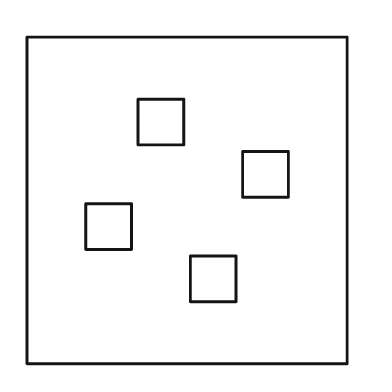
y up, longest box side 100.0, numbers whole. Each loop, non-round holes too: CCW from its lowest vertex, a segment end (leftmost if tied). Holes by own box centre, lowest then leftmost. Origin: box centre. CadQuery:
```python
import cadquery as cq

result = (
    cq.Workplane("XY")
    .moveTo(-49.0, -50.0)
    .lineTo(49.0, -50.0)
    .lineTo(49.0, 50.0)
    .lineTo(-49.0, 50.0)
    .close()
    .moveTo(1.0, -31.0)
    .lineTo(15.0, -31.0)
    .lineTo(15.0, -17.0)
    .lineTo(1.0, -17.0)
    .close()
    .moveTo(-31.0, -15.0)
    .lineTo(-17.0, -15.0)
    .lineTo(-17.0, -1.0)
    .lineTo(-31.0, -1.0)
    .close()
    .moveTo(17.0, 1.0)
    .lineTo(31.0, 1.0)
    .lineTo(31.0, 15.0)
    .lineTo(17.0, 15.0)
    .close()
    .moveTo(-15.0, 17.0)
    .lineTo(-1.0, 17.0)
    .lineTo(-1.0, 31.0)
    .lineTo(-15.0, 31.0)
    .close()
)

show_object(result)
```